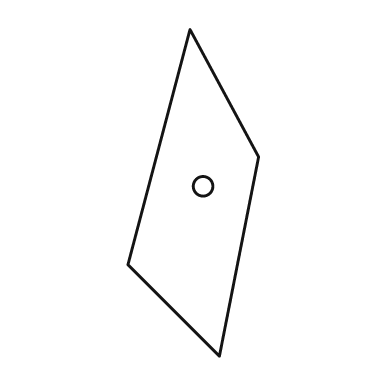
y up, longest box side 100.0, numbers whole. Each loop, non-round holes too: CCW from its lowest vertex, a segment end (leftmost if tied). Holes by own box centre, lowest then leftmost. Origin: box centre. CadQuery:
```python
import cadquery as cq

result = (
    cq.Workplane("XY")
    .moveTo(8.0, -50.0)
    .lineTo(20.0, 11.0)
    .lineTo(-1.0, 50.0)
    .lineTo(-20.0, -22.0)
    .close()
    .moveTo(3.0, 2.0)
    .circle(3.0)
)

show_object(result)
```